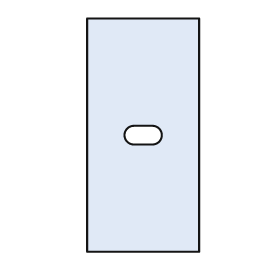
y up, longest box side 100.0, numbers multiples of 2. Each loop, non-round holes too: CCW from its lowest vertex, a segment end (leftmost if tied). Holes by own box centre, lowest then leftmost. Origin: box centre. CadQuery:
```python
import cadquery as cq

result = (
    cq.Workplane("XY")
    .moveTo(-24.0, -50.0)
    .lineTo(24.0, -50.0)
    .lineTo(24.0, 50.0)
    .lineTo(-24.0, 50.0)
    .close()
    .moveTo(-4.0, -4.0)
    .lineTo(4.0, -4.0)
    .threePointArc((8.0, 0.0), (4.0, 4.0))
    .lineTo(-4.0, 4.0)
    .threePointArc((-8.0, 0.0), (-4.0, -4.0))
    .close()
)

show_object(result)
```